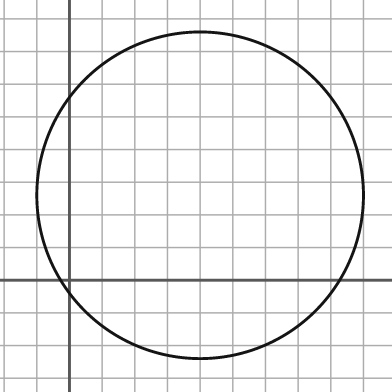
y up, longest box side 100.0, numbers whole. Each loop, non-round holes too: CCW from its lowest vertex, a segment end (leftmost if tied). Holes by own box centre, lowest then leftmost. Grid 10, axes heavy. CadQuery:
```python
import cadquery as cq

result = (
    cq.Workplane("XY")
    .moveTo(40.0, 26.0)
    .circle(50.0)
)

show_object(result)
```